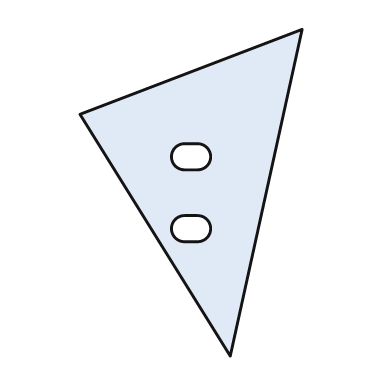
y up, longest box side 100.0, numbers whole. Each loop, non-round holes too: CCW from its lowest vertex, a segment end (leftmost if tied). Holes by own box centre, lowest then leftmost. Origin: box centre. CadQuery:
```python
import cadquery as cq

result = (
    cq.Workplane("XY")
    .moveTo(12.0, -50.0)
    .lineTo(34.0, 50.0)
    .lineTo(-34.0, 24.0)
    .close()
    .moveTo(-2.0, -15.0)
    .lineTo(2.0, -15.0)
    .threePointArc((6.0, -11.0), (2.0, -7.0))
    .lineTo(-2.0, -7.0)
    .threePointArc((-6.0, -11.0), (-2.0, -15.0))
    .close()
    .moveTo(-2.0, 7.0)
    .lineTo(2.0, 7.0)
    .threePointArc((6.0, 11.0), (2.0, 15.0))
    .lineTo(-2.0, 15.0)
    .threePointArc((-6.0, 11.0), (-2.0, 7.0))
    .close()
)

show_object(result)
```